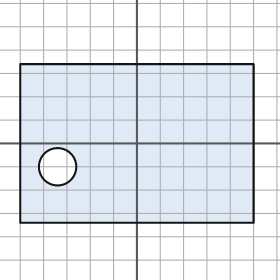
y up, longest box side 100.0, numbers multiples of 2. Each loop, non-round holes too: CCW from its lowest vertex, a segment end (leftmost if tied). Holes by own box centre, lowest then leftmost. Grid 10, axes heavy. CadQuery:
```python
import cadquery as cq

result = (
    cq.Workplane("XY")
    .moveTo(-50.0, -34.0)
    .lineTo(50.0, -34.0)
    .lineTo(50.0, 34.0)
    .lineTo(-50.0, 34.0)
    .close()
    .moveTo(-34.0, -10.0)
    .circle(8.0)
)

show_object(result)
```